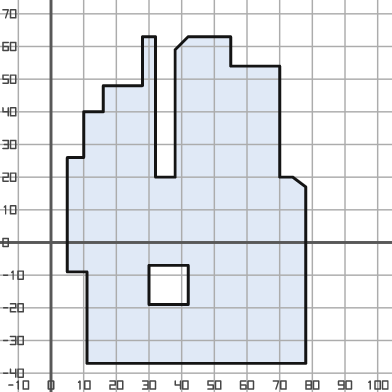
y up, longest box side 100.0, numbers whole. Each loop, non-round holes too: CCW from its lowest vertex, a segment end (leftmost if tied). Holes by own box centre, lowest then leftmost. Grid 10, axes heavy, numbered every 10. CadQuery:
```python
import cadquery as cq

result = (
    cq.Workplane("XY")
    .moveTo(11.0, -37.0)
    .lineTo(78.0, -37.0)
    .lineTo(78.0, 17.0)
    .lineTo(74.0, 20.0)
    .lineTo(70.0, 20.0)
    .lineTo(70.0, 54.0)
    .lineTo(55.0, 54.0)
    .lineTo(55.0, 63.0)
    .lineTo(42.0, 63.0)
    .lineTo(38.0, 59.0)
    .lineTo(38.0, 20.0)
    .lineTo(32.0, 20.0)
    .lineTo(32.0, 63.0)
    .lineTo(28.0, 63.0)
    .lineTo(28.0, 48.0)
    .lineTo(16.0, 48.0)
    .lineTo(16.0, 40.0)
    .lineTo(10.0, 40.0)
    .lineTo(10.0, 26.0)
    .lineTo(5.0, 26.0)
    .lineTo(5.0, -9.0)
    .lineTo(11.0, -9.0)
    .close()
    .moveTo(30.0, -19.0)
    .lineTo(42.0, -19.0)
    .lineTo(42.0, -7.0)
    .lineTo(30.0, -7.0)
    .close()
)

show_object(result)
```